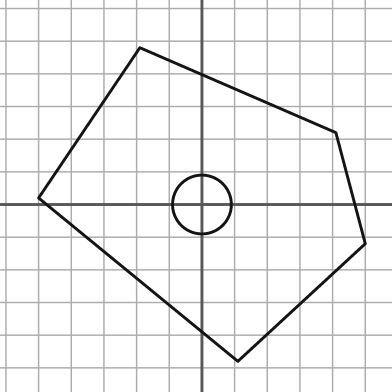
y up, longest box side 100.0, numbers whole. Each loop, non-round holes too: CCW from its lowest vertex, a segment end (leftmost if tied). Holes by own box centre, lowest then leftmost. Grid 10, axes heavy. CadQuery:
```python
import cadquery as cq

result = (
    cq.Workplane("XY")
    .moveTo(11.0, -48.0)
    .lineTo(50.0, -12.0)
    .lineTo(41.0, 22.0)
    .lineTo(-19.0, 48.0)
    .lineTo(-50.0, 2.0)
    .close()
    .moveTo(0.0, 0.0)
    .circle(9.0)
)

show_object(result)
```